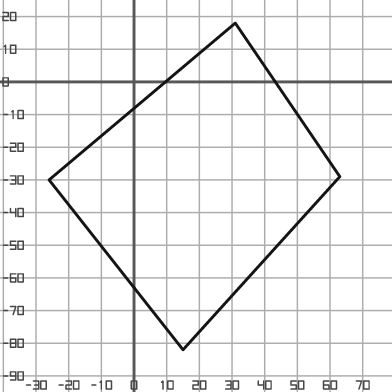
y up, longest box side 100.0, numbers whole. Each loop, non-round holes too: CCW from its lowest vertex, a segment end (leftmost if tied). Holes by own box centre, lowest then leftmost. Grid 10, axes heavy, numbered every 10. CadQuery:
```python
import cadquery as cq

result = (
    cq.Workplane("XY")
    .moveTo(15.0, -82.0)
    .lineTo(63.0, -29.0)
    .lineTo(31.0, 18.0)
    .lineTo(-26.0, -30.0)
    .close()
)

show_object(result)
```